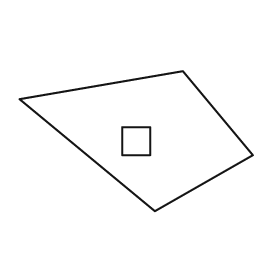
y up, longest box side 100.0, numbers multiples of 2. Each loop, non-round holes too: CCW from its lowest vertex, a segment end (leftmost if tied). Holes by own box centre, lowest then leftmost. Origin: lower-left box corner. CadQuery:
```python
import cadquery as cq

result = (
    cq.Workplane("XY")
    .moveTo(58.0, 0.0)
    .lineTo(100.0, 24.0)
    .lineTo(70.0, 60.0)
    .lineTo(0.0, 48.0)
    .close()
    .moveTo(44.0, 24.0)
    .lineTo(56.0, 24.0)
    .lineTo(56.0, 36.0)
    .lineTo(44.0, 36.0)
    .close()
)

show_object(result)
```